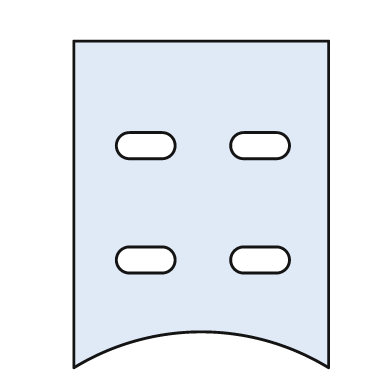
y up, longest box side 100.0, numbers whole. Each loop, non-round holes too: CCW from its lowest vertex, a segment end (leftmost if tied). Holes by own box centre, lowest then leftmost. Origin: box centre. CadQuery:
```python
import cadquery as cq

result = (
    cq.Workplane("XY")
    .moveTo(-39.0, -50.0)
    .threePointArc((0.0, -39.0), (39.0, -50.0))
    .lineTo(39.0, 50.0)
    .lineTo(-39.0, 50.0)
    .close()
    .moveTo(-22.0, -21.0)
    .lineTo(-12.0, -21.0)
    .threePointArc((-8.0, -17.0), (-12.0, -13.0))
    .lineTo(-22.0, -13.0)
    .threePointArc((-26.0, -17.0), (-22.0, -21.0))
    .close()
    .moveTo(13.0, -21.0)
    .lineTo(23.0, -21.0)
    .threePointArc((27.0, -17.0), (23.0, -13.0))
    .lineTo(13.0, -13.0)
    .threePointArc((9.0, -17.0), (13.0, -21.0))
    .close()
    .moveTo(-22.0, 14.0)
    .lineTo(-12.0, 14.0)
    .threePointArc((-8.0, 18.0), (-12.0, 22.0))
    .lineTo(-22.0, 22.0)
    .threePointArc((-26.0, 18.0), (-22.0, 14.0))
    .close()
    .moveTo(13.0, 14.0)
    .lineTo(23.0, 14.0)
    .threePointArc((27.0, 18.0), (23.0, 22.0))
    .lineTo(13.0, 22.0)
    .threePointArc((9.0, 18.0), (13.0, 14.0))
    .close()
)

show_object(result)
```